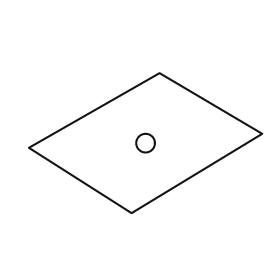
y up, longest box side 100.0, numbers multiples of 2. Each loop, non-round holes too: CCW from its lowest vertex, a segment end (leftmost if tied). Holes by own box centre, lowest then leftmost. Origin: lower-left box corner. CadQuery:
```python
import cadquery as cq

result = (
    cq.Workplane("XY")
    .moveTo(44.0, 0.0)
    .lineTo(100.0, 34.0)
    .lineTo(56.0, 60.0)
    .lineTo(0.0, 28.0)
    .close()
    .moveTo(50.0, 30.0)
    .circle(4.0)
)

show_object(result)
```